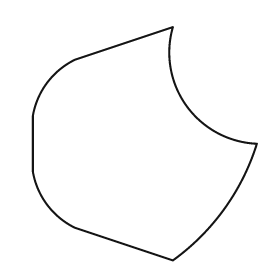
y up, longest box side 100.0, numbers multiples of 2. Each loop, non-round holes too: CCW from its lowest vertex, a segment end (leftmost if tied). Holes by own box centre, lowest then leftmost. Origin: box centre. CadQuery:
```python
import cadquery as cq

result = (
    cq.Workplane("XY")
    .moveTo(12.0, -50.0)
    .threePointArc((34.0, -28.0), (48.0, 0.0))
    .threePointArc((18.0, 16.0), (12.0, 50.0))
    .lineTo(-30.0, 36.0)
    .threePointArc((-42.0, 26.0), (-48.0, 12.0))
    .lineTo(-48.0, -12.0)
    .threePointArc((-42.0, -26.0), (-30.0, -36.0))
    .close()
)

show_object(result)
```